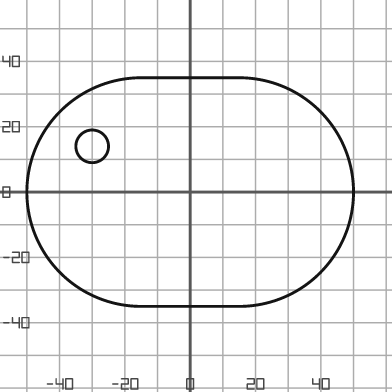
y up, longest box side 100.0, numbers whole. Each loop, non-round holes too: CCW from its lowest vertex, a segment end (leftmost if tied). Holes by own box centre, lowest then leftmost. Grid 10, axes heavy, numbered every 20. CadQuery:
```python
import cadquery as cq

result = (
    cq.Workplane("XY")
    .moveTo(-15.0, -35.0)
    .lineTo(15.0, -35.0)
    .threePointArc((50.0, 0.0), (15.0, 35.0))
    .lineTo(-15.0, 35.0)
    .threePointArc((-50.0, 0.0), (-15.0, -35.0))
    .close()
    .moveTo(-30.0, 14.0)
    .circle(5.0)
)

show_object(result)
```